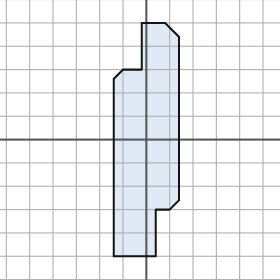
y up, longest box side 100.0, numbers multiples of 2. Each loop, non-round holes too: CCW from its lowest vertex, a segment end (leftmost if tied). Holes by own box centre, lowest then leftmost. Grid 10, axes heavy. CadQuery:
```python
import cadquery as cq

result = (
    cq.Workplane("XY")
    .moveTo(-14.0, -50.0)
    .lineTo(4.0, -50.0)
    .lineTo(4.0, -30.0)
    .lineTo(10.0, -30.0)
    .lineTo(14.0, -26.0)
    .lineTo(14.0, 44.0)
    .lineTo(8.0, 50.0)
    .lineTo(-2.0, 50.0)
    .lineTo(-2.0, 30.0)
    .lineTo(-10.0, 30.0)
    .lineTo(-14.0, 26.0)
    .close()
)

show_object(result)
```